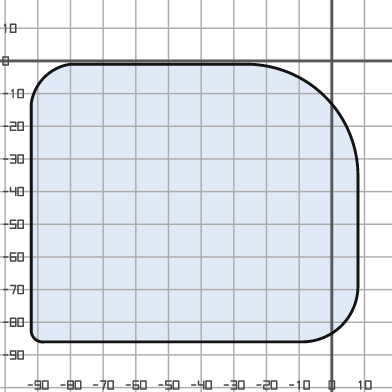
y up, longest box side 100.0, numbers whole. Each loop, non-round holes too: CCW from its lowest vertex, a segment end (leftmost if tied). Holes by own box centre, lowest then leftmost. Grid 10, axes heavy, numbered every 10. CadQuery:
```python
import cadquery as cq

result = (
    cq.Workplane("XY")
    .moveTo(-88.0, -86.0)
    .lineTo(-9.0, -86.0)
    .threePointArc((3.0, -81.0), (8.0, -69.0))
    .lineTo(8.0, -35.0)
    .threePointArc((-2.0, -11.0), (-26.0, -1.0))
    .lineTo(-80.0, -1.0)
    .threePointArc((-88.0, -5.0), (-92.0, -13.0))
    .lineTo(-92.0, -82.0)
    .threePointArc((-91.0, -85.0), (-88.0, -86.0))
    .close()
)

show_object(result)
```